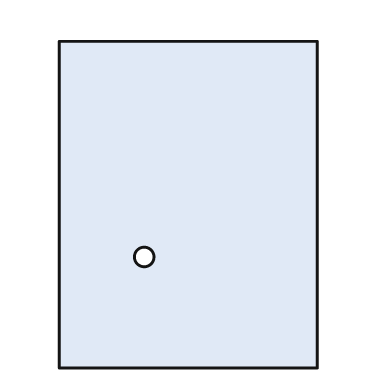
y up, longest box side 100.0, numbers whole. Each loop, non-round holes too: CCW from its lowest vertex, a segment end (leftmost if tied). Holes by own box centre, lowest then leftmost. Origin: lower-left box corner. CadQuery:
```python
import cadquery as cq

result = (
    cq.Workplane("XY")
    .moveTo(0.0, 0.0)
    .lineTo(79.0, 0.0)
    .lineTo(79.0, 100.0)
    .lineTo(0.0, 100.0)
    .close()
    .moveTo(26.0, 34.0)
    .circle(3.0)
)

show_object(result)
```